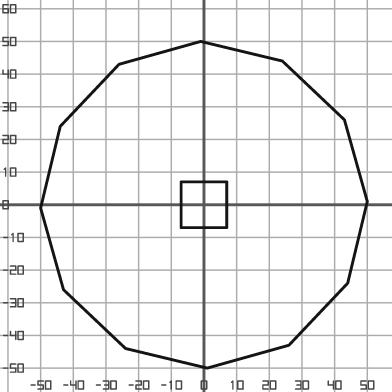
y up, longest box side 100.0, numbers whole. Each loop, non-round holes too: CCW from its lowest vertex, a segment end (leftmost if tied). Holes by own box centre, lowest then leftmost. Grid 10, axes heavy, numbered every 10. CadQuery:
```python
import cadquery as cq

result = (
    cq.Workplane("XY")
    .moveTo(1.0, -50.0)
    .lineTo(26.0, -43.0)
    .lineTo(44.0, -24.0)
    .lineTo(50.0, 1.0)
    .lineTo(43.0, 26.0)
    .lineTo(24.0, 44.0)
    .lineTo(-1.0, 50.0)
    .lineTo(-26.0, 43.0)
    .lineTo(-44.0, 24.0)
    .lineTo(-50.0, -1.0)
    .lineTo(-43.0, -26.0)
    .lineTo(-24.0, -44.0)
    .close()
    .moveTo(-7.0, -7.0)
    .lineTo(7.0, -7.0)
    .lineTo(7.0, 7.0)
    .lineTo(-7.0, 7.0)
    .close()
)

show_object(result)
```